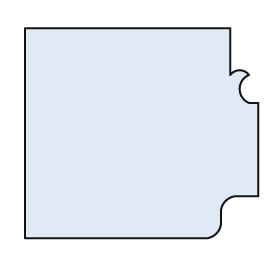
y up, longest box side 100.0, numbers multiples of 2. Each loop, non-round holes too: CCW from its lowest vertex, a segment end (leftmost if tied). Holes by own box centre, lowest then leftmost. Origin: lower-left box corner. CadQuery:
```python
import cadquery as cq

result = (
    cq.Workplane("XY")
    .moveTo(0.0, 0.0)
    .lineTo(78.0, 0.0)
    .threePointArc((82.0, 2.0), (84.0, 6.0))
    .lineTo(84.0, 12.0)
    .threePointArc((86.0, 16.0), (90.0, 18.0))
    .lineTo(100.0, 18.0)
    .lineTo(100.0, 58.0)
    .lineTo(96.0, 58.0)
    .threePointArc((92.0, 64.0), (96.0, 70.0))
    .threePointArc((92.0, 72.0), (88.0, 70.0))
    .lineTo(88.0, 90.0)
    .lineTo(0.0, 90.0)
    .close()
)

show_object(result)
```